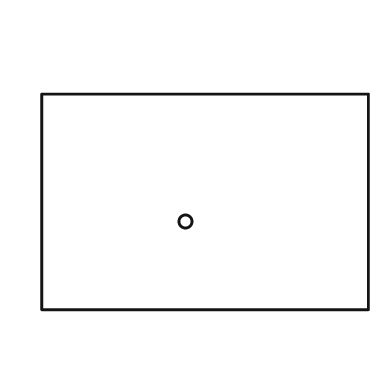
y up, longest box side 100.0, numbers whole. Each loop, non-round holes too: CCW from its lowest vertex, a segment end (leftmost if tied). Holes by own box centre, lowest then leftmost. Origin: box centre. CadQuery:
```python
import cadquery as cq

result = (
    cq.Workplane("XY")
    .moveTo(-50.0, -33.0)
    .lineTo(50.0, -33.0)
    .lineTo(50.0, 33.0)
    .lineTo(-50.0, 33.0)
    .close()
    .moveTo(-6.0, -6.0)
    .circle(2.0)
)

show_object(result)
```